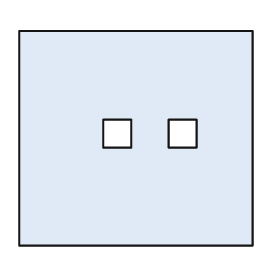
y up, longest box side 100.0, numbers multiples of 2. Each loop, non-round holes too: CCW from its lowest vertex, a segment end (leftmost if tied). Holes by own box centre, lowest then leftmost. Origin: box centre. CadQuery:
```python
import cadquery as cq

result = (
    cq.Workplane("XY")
    .moveTo(-50.0, -46.0)
    .lineTo(50.0, -46.0)
    .lineTo(50.0, 46.0)
    .lineTo(-50.0, 46.0)
    .close()
    .moveTo(-14.0, -4.0)
    .lineTo(-2.0, -4.0)
    .lineTo(-2.0, 8.0)
    .lineTo(-14.0, 8.0)
    .close()
    .moveTo(14.0, -4.0)
    .lineTo(26.0, -4.0)
    .lineTo(26.0, 8.0)
    .lineTo(14.0, 8.0)
    .close()
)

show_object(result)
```